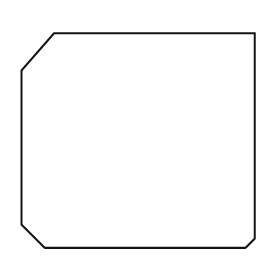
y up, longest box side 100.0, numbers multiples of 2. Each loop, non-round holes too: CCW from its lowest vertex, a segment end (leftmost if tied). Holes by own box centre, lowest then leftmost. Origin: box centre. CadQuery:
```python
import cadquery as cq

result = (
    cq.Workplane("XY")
    .moveTo(-40.0, -46.0)
    .lineTo(46.0, -46.0)
    .lineTo(50.0, -42.0)
    .lineTo(50.0, 46.0)
    .lineTo(-36.0, 46.0)
    .lineTo(-50.0, 30.0)
    .lineTo(-50.0, -36.0)
    .close()
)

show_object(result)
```